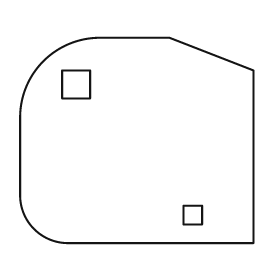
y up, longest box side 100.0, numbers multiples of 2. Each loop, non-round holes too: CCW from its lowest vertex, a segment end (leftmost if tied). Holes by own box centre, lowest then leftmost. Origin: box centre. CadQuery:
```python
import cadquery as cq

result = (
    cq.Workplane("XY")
    .moveTo(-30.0, -44.0)
    .lineTo(50.0, -44.0)
    .lineTo(50.0, 30.0)
    .lineTo(14.0, 44.0)
    .lineTo(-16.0, 44.0)
    .threePointArc((-40.0, 34.0), (-50.0, 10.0))
    .lineTo(-50.0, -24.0)
    .threePointArc((-44.0, -38.0), (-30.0, -44.0))
    .close()
    .moveTo(20.0, -36.0)
    .lineTo(28.0, -36.0)
    .lineTo(28.0, -28.0)
    .lineTo(20.0, -28.0)
    .close()
    .moveTo(-32.0, 18.0)
    .lineTo(-20.0, 18.0)
    .lineTo(-20.0, 30.0)
    .lineTo(-32.0, 30.0)
    .close()
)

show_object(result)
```